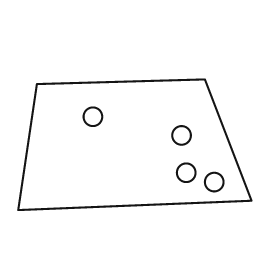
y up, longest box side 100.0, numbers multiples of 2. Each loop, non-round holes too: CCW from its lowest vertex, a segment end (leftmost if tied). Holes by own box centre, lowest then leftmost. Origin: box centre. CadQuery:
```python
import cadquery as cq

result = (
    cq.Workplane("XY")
    .moveTo(-50.0, -28.0)
    .lineTo(50.0, -24.0)
    .lineTo(30.0, 28.0)
    .lineTo(-42.0, 26.0)
    .close()
    .moveTo(34.0, -16.0)
    .circle(4.0)
    .moveTo(22.0, -12.0)
    .circle(4.0)
    .moveTo(20.0, 4.0)
    .circle(4.0)
    .moveTo(-18.0, 12.0)
    .circle(4.0)
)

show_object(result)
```